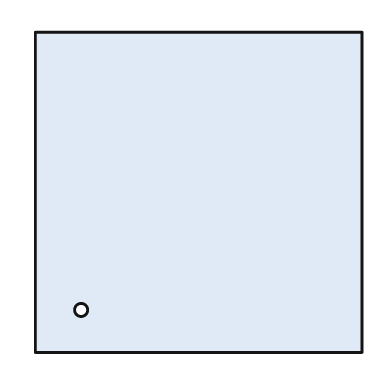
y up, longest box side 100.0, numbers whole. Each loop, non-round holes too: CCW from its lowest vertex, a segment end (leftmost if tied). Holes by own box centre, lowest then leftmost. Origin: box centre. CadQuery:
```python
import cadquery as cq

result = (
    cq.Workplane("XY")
    .moveTo(-50.0, -49.0)
    .lineTo(50.0, -49.0)
    .lineTo(50.0, 49.0)
    .lineTo(-50.0, 49.0)
    .close()
    .moveTo(-36.0, -36.0)
    .circle(2.0)
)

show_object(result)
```